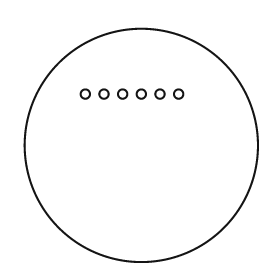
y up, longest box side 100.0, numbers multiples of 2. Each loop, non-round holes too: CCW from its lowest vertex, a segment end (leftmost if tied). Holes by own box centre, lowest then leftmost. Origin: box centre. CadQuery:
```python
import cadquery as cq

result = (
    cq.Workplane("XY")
    .moveTo(0.0, 0.0)
    .circle(50.0)
    .moveTo(-24.0, 22.0)
    .circle(2.0)
    .moveTo(-16.0, 22.0)
    .circle(2.0)
    .moveTo(-8.0, 22.0)
    .circle(2.0)
    .moveTo(0.0, 22.0)
    .circle(2.0)
    .moveTo(8.0, 22.0)
    .circle(2.0)
    .moveTo(16.0, 22.0)
    .circle(2.0)
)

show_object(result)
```